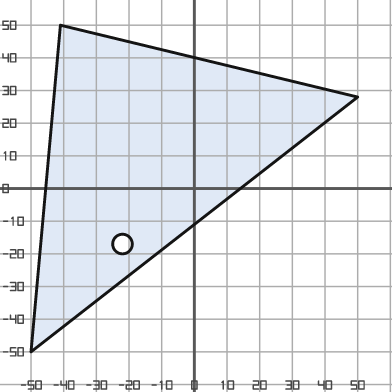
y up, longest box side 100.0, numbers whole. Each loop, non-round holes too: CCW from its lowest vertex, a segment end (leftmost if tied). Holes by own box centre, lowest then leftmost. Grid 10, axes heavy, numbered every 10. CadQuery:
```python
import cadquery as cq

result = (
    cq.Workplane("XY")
    .moveTo(-50.0, -50.0)
    .lineTo(50.0, 28.0)
    .lineTo(-41.0, 50.0)
    .close()
    .moveTo(-22.0, -17.0)
    .circle(3.0)
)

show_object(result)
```